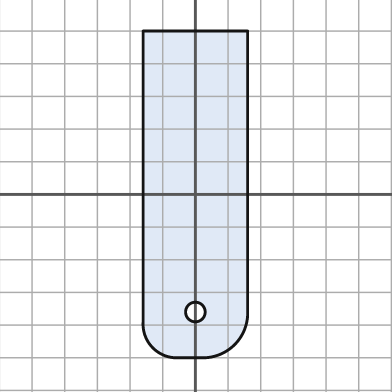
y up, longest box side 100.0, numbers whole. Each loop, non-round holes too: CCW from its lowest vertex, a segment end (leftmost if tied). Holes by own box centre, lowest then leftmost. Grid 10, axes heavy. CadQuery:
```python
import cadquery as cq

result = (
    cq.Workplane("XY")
    .moveTo(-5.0, -50.0)
    .lineTo(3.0, -50.0)
    .threePointArc((12.0, -46.0), (16.0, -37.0))
    .lineTo(16.0, 50.0)
    .lineTo(-16.0, 50.0)
    .lineTo(-16.0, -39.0)
    .threePointArc((-13.0, -47.0), (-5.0, -50.0))
    .close()
    .moveTo(0.0, -36.0)
    .circle(3.0)
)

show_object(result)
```